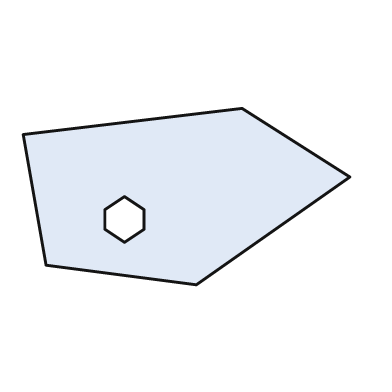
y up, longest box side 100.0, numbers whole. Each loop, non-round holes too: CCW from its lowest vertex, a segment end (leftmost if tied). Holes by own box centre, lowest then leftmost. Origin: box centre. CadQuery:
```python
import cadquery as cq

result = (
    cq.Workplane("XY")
    .moveTo(3.0, -27.0)
    .lineTo(50.0, 6.0)
    .lineTo(17.0, 27.0)
    .lineTo(-50.0, 19.0)
    .lineTo(-43.0, -21.0)
    .close()
    .moveTo(-19.0, -14.0)
    .lineTo(-13.0, -10.0)
    .lineTo(-13.0, -4.0)
    .lineTo(-19.0, 0.0)
    .lineTo(-25.0, -4.0)
    .lineTo(-25.0, -10.0)
    .close()
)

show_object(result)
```